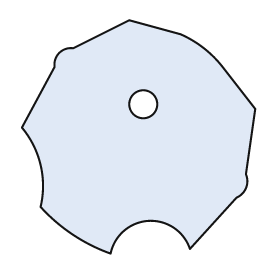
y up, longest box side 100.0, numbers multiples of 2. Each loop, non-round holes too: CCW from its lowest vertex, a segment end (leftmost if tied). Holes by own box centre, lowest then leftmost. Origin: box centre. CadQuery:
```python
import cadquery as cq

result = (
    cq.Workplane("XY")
    .moveTo(-12.0, -50.0)
    .threePointArc((4.0, -36.0), (22.0, -48.0))
    .lineTo(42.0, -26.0)
    .threePointArc((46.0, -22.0), (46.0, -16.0))
    .lineTo(50.0, 12.0)
    .lineTo(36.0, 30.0)
    .threePointArc((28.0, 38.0), (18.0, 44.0))
    .lineTo(-4.0, 50.0)
    .lineTo(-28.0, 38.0)
    .threePointArc((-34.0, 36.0), (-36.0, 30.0))
    .lineTo(-50.0, 4.0)
    .threePointArc((-42.0, -12.0), (-42.0, -30.0))
    .threePointArc((-28.0, -42.0), (-12.0, -50.0))
    .close()
    .moveTo(2.0, 14.0)
    .circle(6.0)
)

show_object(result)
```